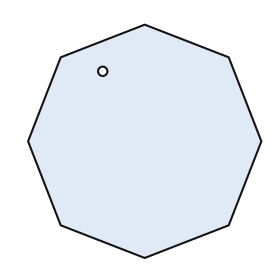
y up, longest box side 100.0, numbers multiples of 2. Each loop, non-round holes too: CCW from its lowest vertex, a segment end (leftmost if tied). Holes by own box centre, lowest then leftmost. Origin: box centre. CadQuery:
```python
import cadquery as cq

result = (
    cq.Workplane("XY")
    .moveTo(0.0, -50.0)
    .lineTo(36.0, -36.0)
    .lineTo(50.0, 0.0)
    .lineTo(36.0, 36.0)
    .lineTo(0.0, 50.0)
    .lineTo(-36.0, 36.0)
    .lineTo(-50.0, 0.0)
    .lineTo(-36.0, -36.0)
    .close()
    .moveTo(-18.0, 30.0)
    .circle(2.0)
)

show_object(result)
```